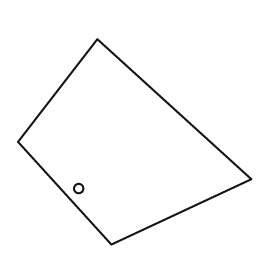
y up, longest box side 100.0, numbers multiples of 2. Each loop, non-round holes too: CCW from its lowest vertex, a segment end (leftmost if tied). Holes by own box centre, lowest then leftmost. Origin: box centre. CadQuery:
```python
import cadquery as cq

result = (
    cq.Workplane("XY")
    .moveTo(-10.0, -44.0)
    .lineTo(50.0, -16.0)
    .lineTo(-16.0, 44.0)
    .lineTo(-50.0, 0.0)
    .close()
    .moveTo(-24.0, -20.0)
    .circle(2.0)
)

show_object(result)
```